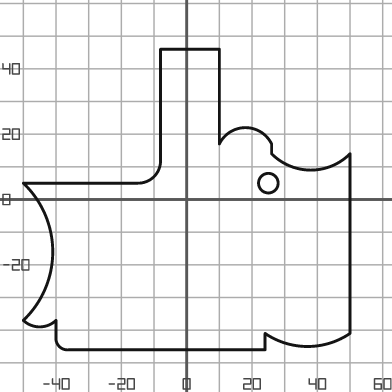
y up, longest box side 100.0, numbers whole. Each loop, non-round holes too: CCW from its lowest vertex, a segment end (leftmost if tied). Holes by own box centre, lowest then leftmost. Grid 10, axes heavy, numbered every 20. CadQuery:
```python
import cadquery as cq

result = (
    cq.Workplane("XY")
    .moveTo(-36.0, -46.0)
    .lineTo(24.0, -46.0)
    .lineTo(24.0, -41.0)
    .threePointArc((37.0, -45.0), (50.0, -41.0))
    .lineTo(50.0, 14.0)
    .threePointArc((38.0, 9.0), (26.0, 14.0))
    .lineTo(26.0, 17.0)
    .threePointArc((18.0, 22.0), (10.0, 17.0))
    .lineTo(10.0, 46.0)
    .lineTo(-8.0, 46.0)
    .lineTo(-8.0, 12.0)
    .threePointArc((-10.0, 7.0), (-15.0, 5.0))
    .lineTo(-50.0, 5.0)
    .threePointArc((-41.0, -16.0), (-50.0, -37.0))
    .threePointArc((-45.0, -39.0), (-40.0, -37.0))
    .lineTo(-40.0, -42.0)
    .threePointArc((-39.0, -45.0), (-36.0, -46.0))
    .close()
    .moveTo(25.0, 5.0)
    .circle(3.0)
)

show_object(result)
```